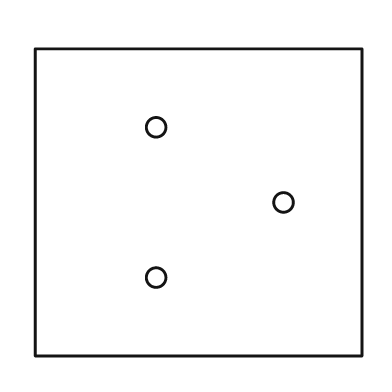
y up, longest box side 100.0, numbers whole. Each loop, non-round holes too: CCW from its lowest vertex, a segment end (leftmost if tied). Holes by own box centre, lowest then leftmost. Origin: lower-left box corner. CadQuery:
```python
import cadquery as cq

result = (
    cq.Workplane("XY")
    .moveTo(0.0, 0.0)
    .lineTo(100.0, 0.0)
    .lineTo(100.0, 94.0)
    .lineTo(0.0, 94.0)
    .close()
    .moveTo(37.0, 24.0)
    .circle(3.0)
    .moveTo(76.0, 47.0)
    .circle(3.0)
    .moveTo(37.0, 70.0)
    .circle(3.0)
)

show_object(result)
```